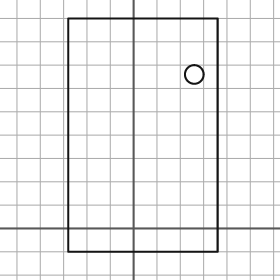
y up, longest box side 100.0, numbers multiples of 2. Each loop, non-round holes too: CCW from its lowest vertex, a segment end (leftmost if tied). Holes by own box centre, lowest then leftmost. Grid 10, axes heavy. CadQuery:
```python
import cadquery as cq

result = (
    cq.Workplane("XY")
    .moveTo(-28.0, -10.0)
    .lineTo(36.0, -10.0)
    .lineTo(36.0, 90.0)
    .lineTo(-28.0, 90.0)
    .close()
    .moveTo(26.0, 66.0)
    .circle(4.0)
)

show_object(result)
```